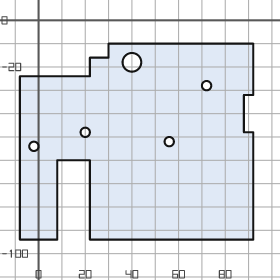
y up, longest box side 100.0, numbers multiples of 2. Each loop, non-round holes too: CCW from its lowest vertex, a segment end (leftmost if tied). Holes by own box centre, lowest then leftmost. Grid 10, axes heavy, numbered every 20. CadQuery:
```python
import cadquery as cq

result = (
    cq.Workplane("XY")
    .moveTo(-8.0, -94.0)
    .lineTo(8.0, -94.0)
    .lineTo(8.0, -60.0)
    .lineTo(22.0, -60.0)
    .lineTo(22.0, -94.0)
    .lineTo(92.0, -94.0)
    .lineTo(92.0, -48.0)
    .lineTo(88.0, -48.0)
    .lineTo(88.0, -32.0)
    .lineTo(92.0, -32.0)
    .lineTo(92.0, -10.0)
    .lineTo(30.0, -10.0)
    .lineTo(30.0, -16.0)
    .lineTo(22.0, -16.0)
    .lineTo(22.0, -24.0)
    .lineTo(-8.0, -24.0)
    .close()
    .moveTo(-2.0, -54.0)
    .circle(2.0)
    .moveTo(56.0, -52.0)
    .circle(2.0)
    .moveTo(20.0, -48.0)
    .circle(2.0)
    .moveTo(72.0, -28.0)
    .circle(2.0)
    .moveTo(40.0, -18.0)
    .circle(4.0)
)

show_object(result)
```